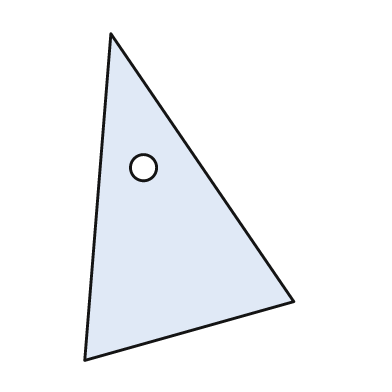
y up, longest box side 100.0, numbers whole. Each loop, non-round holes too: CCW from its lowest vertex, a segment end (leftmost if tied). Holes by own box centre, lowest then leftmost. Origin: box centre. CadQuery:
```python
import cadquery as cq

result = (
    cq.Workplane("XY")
    .moveTo(-32.0, -50.0)
    .lineTo(32.0, -32.0)
    .lineTo(-24.0, 50.0)
    .close()
    .moveTo(-14.0, 9.0)
    .circle(4.0)
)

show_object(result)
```